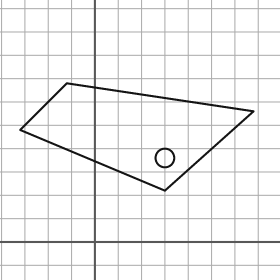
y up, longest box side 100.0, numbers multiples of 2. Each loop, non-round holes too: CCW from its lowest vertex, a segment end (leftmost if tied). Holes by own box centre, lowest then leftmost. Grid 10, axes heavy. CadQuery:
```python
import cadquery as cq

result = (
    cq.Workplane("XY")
    .moveTo(30.0, 22.0)
    .lineTo(68.0, 56.0)
    .lineTo(-12.0, 68.0)
    .lineTo(-32.0, 48.0)
    .close()
    .moveTo(30.0, 36.0)
    .circle(4.0)
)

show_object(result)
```